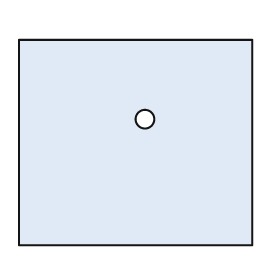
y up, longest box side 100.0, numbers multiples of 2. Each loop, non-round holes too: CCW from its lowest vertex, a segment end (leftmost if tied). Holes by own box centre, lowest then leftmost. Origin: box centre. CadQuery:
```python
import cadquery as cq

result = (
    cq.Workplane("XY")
    .moveTo(-50.0, -44.0)
    .lineTo(50.0, -44.0)
    .lineTo(50.0, 44.0)
    .lineTo(-50.0, 44.0)
    .close()
    .moveTo(4.0, 10.0)
    .circle(4.0)
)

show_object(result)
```